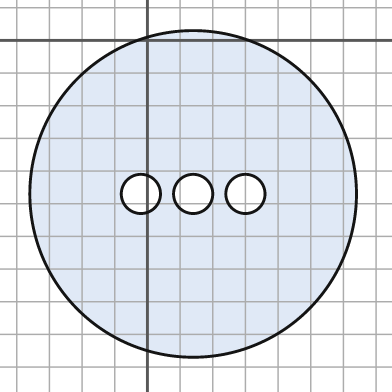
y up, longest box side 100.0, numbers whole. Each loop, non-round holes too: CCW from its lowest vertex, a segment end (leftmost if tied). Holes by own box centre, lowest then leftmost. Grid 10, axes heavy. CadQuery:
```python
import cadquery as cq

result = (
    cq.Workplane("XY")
    .moveTo(14.0, -47.0)
    .circle(50.0)
    .moveTo(-2.0, -47.0)
    .circle(6.0)
    .moveTo(14.0, -47.0)
    .circle(6.0)
    .moveTo(30.0, -47.0)
    .circle(6.0)
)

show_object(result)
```